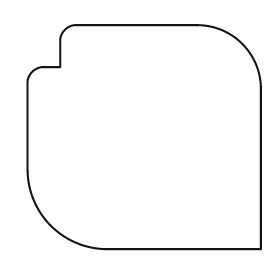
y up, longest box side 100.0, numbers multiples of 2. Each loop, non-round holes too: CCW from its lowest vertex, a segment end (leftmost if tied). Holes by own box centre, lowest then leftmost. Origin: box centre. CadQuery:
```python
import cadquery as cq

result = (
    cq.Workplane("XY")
    .moveTo(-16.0, -48.0)
    .lineTo(50.0, -48.0)
    .lineTo(50.0, 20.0)
    .threePointArc((42.0, 40.0), (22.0, 48.0))
    .lineTo(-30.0, 48.0)
    .threePointArc((-34.0, 46.0), (-36.0, 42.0))
    .lineTo(-36.0, 30.0)
    .lineTo(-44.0, 30.0)
    .threePointArc((-48.0, 28.0), (-50.0, 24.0))
    .lineTo(-50.0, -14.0)
    .threePointArc((-40.0, -38.0), (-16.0, -48.0))
    .close()
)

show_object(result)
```